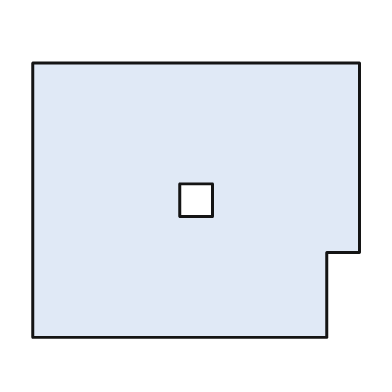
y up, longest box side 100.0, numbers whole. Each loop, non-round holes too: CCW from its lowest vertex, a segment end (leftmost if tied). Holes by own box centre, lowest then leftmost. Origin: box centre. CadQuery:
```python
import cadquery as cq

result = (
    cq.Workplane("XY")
    .moveTo(-50.0, -42.0)
    .lineTo(40.0, -42.0)
    .lineTo(40.0, -16.0)
    .lineTo(50.0, -16.0)
    .lineTo(50.0, 42.0)
    .lineTo(-50.0, 42.0)
    .close()
    .moveTo(-5.0, -5.0)
    .lineTo(5.0, -5.0)
    .lineTo(5.0, 5.0)
    .lineTo(-5.0, 5.0)
    .close()
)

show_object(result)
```